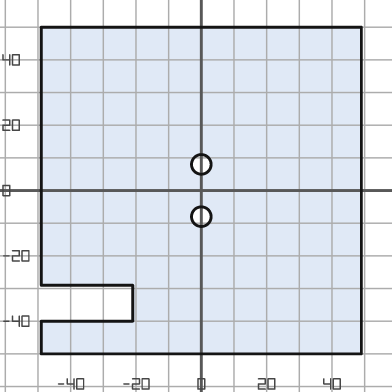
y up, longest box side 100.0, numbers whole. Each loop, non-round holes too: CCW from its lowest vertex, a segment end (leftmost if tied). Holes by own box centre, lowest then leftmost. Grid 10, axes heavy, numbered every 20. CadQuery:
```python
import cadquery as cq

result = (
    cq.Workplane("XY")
    .moveTo(-49.0, -50.0)
    .lineTo(49.0, -50.0)
    .lineTo(49.0, 50.0)
    .lineTo(-49.0, 50.0)
    .lineTo(-49.0, -29.0)
    .lineTo(-21.0, -29.0)
    .lineTo(-21.0, -40.0)
    .lineTo(-49.0, -40.0)
    .close()
    .moveTo(0.0, -8.0)
    .circle(3.0)
    .moveTo(0.0, 8.0)
    .circle(3.0)
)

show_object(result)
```